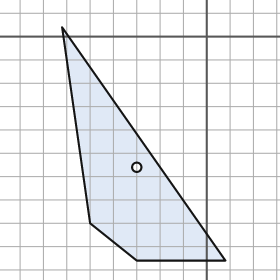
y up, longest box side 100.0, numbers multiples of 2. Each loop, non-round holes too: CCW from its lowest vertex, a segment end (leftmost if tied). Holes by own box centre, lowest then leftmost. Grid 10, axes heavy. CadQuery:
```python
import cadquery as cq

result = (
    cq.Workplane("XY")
    .moveTo(-30.0, -96.0)
    .lineTo(8.0, -96.0)
    .lineTo(-62.0, 4.0)
    .lineTo(-50.0, -80.0)
    .close()
    .moveTo(-30.0, -56.0)
    .circle(2.0)
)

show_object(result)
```